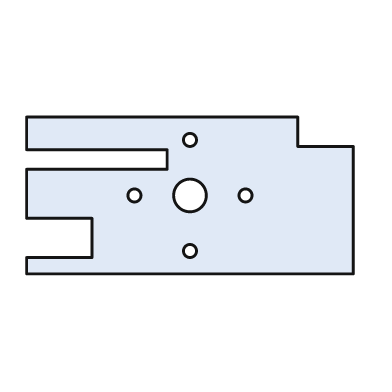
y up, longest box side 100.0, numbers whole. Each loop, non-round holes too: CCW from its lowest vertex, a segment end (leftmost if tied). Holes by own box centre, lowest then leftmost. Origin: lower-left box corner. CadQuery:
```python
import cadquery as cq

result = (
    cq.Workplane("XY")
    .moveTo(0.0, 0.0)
    .lineTo(100.0, 0.0)
    .lineTo(100.0, 39.0)
    .lineTo(83.0, 39.0)
    .lineTo(83.0, 48.0)
    .lineTo(0.0, 48.0)
    .lineTo(0.0, 38.0)
    .lineTo(43.0, 38.0)
    .lineTo(43.0, 32.0)
    .lineTo(0.0, 32.0)
    .lineTo(0.0, 17.0)
    .lineTo(20.0, 17.0)
    .lineTo(20.0, 5.0)
    .lineTo(0.0, 5.0)
    .close()
    .moveTo(50.0, 7.0)
    .circle(2.0)
    .moveTo(33.0, 24.0)
    .circle(2.0)
    .moveTo(50.0, 24.0)
    .circle(5.0)
    .moveTo(67.0, 24.0)
    .circle(2.0)
    .moveTo(50.0, 41.0)
    .circle(2.0)
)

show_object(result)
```